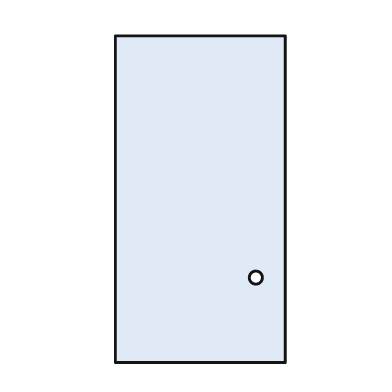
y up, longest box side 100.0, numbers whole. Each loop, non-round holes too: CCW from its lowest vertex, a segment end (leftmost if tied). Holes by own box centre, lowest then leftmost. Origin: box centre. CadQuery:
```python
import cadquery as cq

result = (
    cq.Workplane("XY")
    .moveTo(-26.0, -50.0)
    .lineTo(26.0, -50.0)
    .lineTo(26.0, 50.0)
    .lineTo(-26.0, 50.0)
    .close()
    .moveTo(17.0, -24.0)
    .circle(2.0)
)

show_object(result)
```